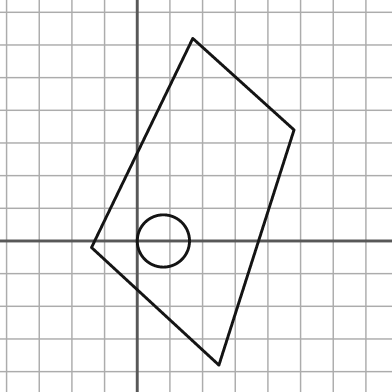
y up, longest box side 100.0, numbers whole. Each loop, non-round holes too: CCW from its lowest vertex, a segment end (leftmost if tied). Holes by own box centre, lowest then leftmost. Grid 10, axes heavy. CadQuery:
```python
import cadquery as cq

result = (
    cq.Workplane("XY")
    .moveTo(25.0, -38.0)
    .lineTo(48.0, 34.0)
    .lineTo(17.0, 62.0)
    .lineTo(-14.0, -2.0)
    .close()
    .moveTo(8.0, 0.0)
    .circle(8.0)
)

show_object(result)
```